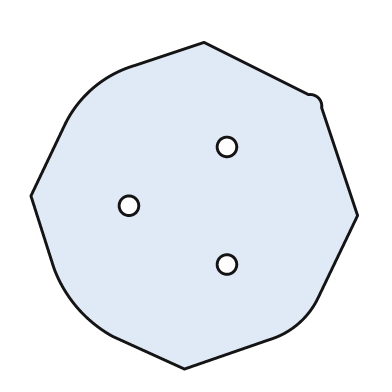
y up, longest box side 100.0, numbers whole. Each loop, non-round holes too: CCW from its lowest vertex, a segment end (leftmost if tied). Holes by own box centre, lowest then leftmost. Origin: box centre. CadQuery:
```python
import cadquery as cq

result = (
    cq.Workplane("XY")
    .moveTo(-3.0, -50.0)
    .lineTo(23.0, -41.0)
    .threePointArc((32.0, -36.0), (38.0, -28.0))
    .lineTo(50.0, -3.0)
    .lineTo(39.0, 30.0)
    .threePointArc((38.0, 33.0), (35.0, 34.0))
    .lineTo(3.0, 50.0)
    .lineTo(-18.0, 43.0)
    .threePointArc((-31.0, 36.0), (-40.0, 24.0))
    .lineTo(-50.0, 3.0)
    .lineTo(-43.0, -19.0)
    .threePointArc((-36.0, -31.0), (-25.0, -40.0))
    .close()
    .moveTo(10.0, -18.0)
    .circle(3.0)
    .moveTo(-20.0, 0.0)
    .circle(3.0)
    .moveTo(10.0, 18.0)
    .circle(3.0)
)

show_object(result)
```